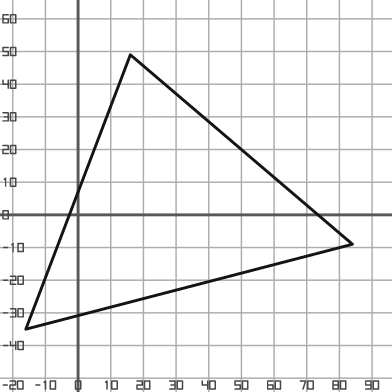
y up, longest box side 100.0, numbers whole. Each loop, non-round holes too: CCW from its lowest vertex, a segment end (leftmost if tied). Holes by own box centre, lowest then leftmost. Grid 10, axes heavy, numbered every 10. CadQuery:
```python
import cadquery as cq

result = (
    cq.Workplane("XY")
    .moveTo(-16.0, -35.0)
    .lineTo(84.0, -9.0)
    .lineTo(16.0, 49.0)
    .close()
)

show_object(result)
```